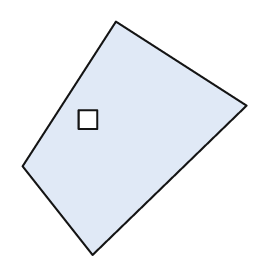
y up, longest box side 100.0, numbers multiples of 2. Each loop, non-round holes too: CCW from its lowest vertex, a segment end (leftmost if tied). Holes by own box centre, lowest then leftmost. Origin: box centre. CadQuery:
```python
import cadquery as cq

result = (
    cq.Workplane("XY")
    .moveTo(-18.0, -50.0)
    .lineTo(48.0, 14.0)
    .lineTo(-8.0, 50.0)
    .lineTo(-48.0, -12.0)
    .close()
    .moveTo(-24.0, 4.0)
    .lineTo(-16.0, 4.0)
    .lineTo(-16.0, 12.0)
    .lineTo(-24.0, 12.0)
    .close()
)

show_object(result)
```